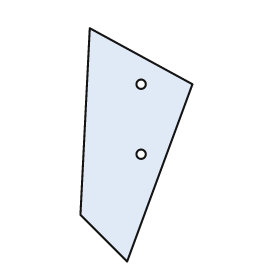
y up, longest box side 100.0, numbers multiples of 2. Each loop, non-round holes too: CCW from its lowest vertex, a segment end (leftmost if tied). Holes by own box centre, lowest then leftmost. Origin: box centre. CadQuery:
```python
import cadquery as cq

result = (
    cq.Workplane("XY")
    .moveTo(-4.0, -50.0)
    .lineTo(24.0, 26.0)
    .lineTo(-20.0, 50.0)
    .lineTo(-24.0, -30.0)
    .close()
    .moveTo(2.0, -4.0)
    .circle(2.0)
    .moveTo(2.0, 26.0)
    .circle(2.0)
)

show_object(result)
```